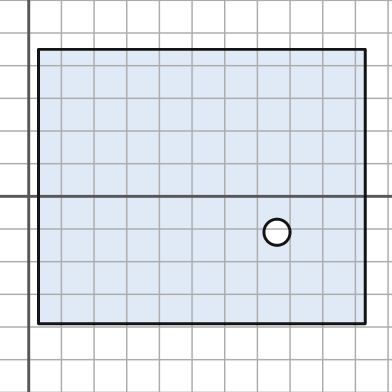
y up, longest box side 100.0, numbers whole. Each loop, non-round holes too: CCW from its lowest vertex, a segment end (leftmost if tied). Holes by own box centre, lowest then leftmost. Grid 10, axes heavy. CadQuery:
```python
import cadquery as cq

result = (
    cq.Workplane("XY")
    .moveTo(3.0, -39.0)
    .lineTo(103.0, -39.0)
    .lineTo(103.0, 45.0)
    .lineTo(3.0, 45.0)
    .close()
    .moveTo(76.0, -11.0)
    .circle(4.0)
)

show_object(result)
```